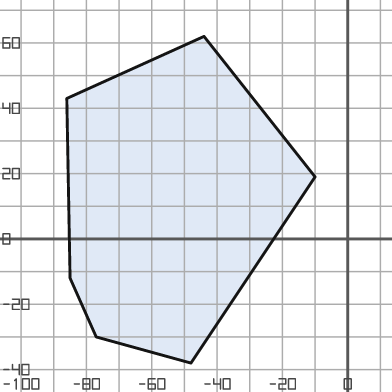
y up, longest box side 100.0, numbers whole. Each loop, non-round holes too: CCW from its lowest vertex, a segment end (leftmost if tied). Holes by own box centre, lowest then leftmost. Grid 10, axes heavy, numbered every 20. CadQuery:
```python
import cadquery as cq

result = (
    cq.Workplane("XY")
    .moveTo(-48.0, -38.0)
    .lineTo(-10.0, 19.0)
    .lineTo(-44.0, 62.0)
    .lineTo(-86.0, 43.0)
    .lineTo(-85.0, -12.0)
    .lineTo(-77.0, -30.0)
    .close()
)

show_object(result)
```